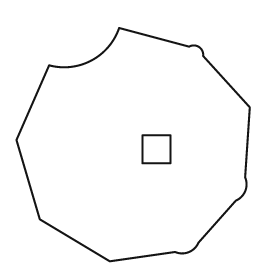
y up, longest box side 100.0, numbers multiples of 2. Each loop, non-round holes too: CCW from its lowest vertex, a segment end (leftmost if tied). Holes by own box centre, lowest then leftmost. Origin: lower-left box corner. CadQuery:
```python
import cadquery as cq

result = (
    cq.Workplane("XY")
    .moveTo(40.0, 0.0)
    .lineTo(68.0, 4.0)
    .threePointArc((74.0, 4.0), (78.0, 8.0))
    .lineTo(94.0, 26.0)
    .threePointArc((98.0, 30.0), (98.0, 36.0))
    .lineTo(100.0, 66.0)
    .lineTo(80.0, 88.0)
    .threePointArc((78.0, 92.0), (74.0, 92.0))
    .lineTo(44.0, 100.0)
    .threePointArc((32.0, 86.0), (14.0, 84.0))
    .lineTo(0.0, 52.0)
    .lineTo(10.0, 18.0)
    .close()
    .moveTo(54.0, 42.0)
    .lineTo(66.0, 42.0)
    .lineTo(66.0, 54.0)
    .lineTo(54.0, 54.0)
    .close()
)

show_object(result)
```